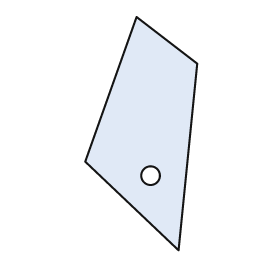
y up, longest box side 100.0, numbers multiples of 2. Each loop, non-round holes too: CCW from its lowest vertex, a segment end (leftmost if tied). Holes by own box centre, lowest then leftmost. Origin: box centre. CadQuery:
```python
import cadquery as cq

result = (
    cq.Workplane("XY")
    .moveTo(16.0, -50.0)
    .lineTo(24.0, 30.0)
    .lineTo(-2.0, 50.0)
    .lineTo(-24.0, -12.0)
    .close()
    .moveTo(4.0, -18.0)
    .circle(4.0)
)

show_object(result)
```